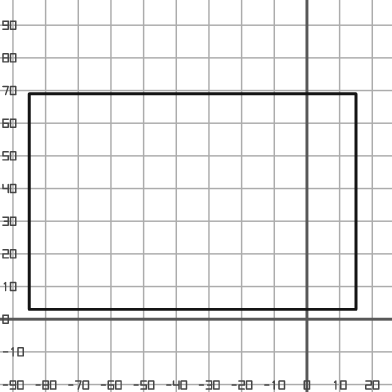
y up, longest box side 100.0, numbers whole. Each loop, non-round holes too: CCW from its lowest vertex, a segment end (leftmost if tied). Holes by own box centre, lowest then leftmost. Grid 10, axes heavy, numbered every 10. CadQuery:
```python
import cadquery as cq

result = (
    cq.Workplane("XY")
    .moveTo(-85.0, 3.0)
    .lineTo(15.0, 3.0)
    .lineTo(15.0, 69.0)
    .lineTo(-85.0, 69.0)
    .close()
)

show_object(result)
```